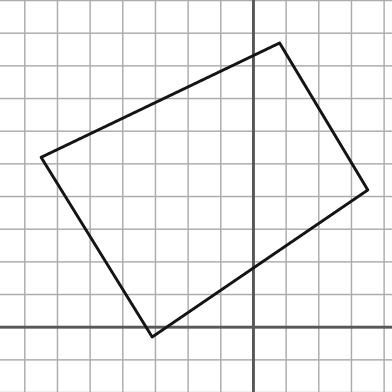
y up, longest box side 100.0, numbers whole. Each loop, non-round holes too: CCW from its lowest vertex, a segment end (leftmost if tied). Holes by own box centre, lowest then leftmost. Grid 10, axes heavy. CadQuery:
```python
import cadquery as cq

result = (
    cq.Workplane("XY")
    .moveTo(-31.0, -3.0)
    .lineTo(35.0, 42.0)
    .lineTo(8.0, 87.0)
    .lineTo(-65.0, 52.0)
    .close()
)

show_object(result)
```